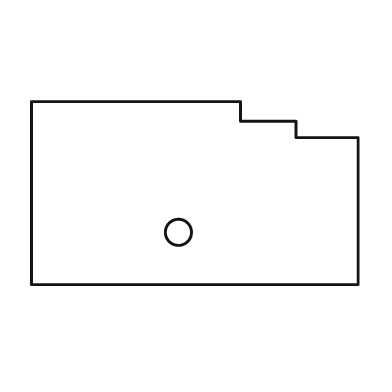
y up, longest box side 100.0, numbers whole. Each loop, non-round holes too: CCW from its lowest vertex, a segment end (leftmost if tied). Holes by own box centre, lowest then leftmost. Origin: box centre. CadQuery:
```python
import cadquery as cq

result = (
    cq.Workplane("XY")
    .moveTo(-50.0, -28.0)
    .lineTo(50.0, -28.0)
    .lineTo(50.0, 17.0)
    .lineTo(31.0, 17.0)
    .lineTo(31.0, 22.0)
    .lineTo(14.0, 22.0)
    .lineTo(14.0, 28.0)
    .lineTo(-50.0, 28.0)
    .close()
    .moveTo(-5.0, -12.0)
    .circle(4.0)
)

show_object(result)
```